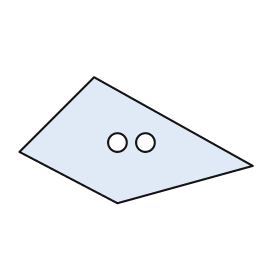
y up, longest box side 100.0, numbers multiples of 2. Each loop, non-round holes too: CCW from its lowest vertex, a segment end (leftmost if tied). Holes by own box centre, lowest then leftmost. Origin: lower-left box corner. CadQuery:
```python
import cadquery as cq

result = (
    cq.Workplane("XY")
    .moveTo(42.0, 0.0)
    .lineTo(100.0, 16.0)
    .lineTo(32.0, 54.0)
    .lineTo(0.0, 22.0)
    .close()
    .moveTo(42.0, 26.0)
    .circle(4.0)
    .moveTo(54.0, 26.0)
    .circle(4.0)
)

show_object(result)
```